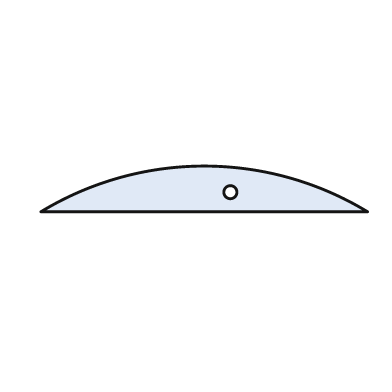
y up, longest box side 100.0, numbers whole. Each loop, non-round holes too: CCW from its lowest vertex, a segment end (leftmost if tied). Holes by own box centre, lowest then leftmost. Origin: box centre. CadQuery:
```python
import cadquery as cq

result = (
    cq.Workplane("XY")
    .moveTo(-50.0, -7.0)
    .lineTo(50.0, -7.0)
    .threePointArc((0.0, 7.0), (-50.0, -7.0))
    .close()
    .moveTo(8.0, -1.0)
    .circle(2.0)
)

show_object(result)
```